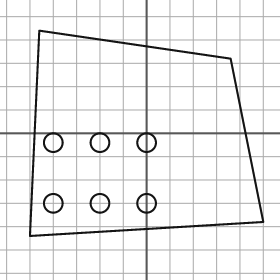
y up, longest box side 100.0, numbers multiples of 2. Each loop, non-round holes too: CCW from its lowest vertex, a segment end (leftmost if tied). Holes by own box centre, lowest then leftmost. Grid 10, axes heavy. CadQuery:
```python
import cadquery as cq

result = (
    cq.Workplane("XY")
    .moveTo(-50.0, -44.0)
    .lineTo(50.0, -38.0)
    .lineTo(36.0, 32.0)
    .lineTo(-46.0, 44.0)
    .close()
    .moveTo(-40.0, -30.0)
    .circle(4.0)
    .moveTo(-20.0, -30.0)
    .circle(4.0)
    .moveTo(0.0, -30.0)
    .circle(4.0)
    .moveTo(-40.0, -4.0)
    .circle(4.0)
    .moveTo(-20.0, -4.0)
    .circle(4.0)
    .moveTo(0.0, -4.0)
    .circle(4.0)
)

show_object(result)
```